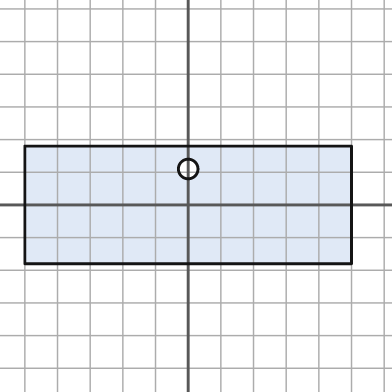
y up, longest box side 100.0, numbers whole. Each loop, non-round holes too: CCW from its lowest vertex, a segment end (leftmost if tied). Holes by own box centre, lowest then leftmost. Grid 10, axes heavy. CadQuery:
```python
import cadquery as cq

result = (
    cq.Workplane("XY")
    .moveTo(-50.0, -18.0)
    .lineTo(50.0, -18.0)
    .lineTo(50.0, 18.0)
    .lineTo(-50.0, 18.0)
    .close()
    .moveTo(0.0, 11.0)
    .circle(3.0)
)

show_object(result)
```